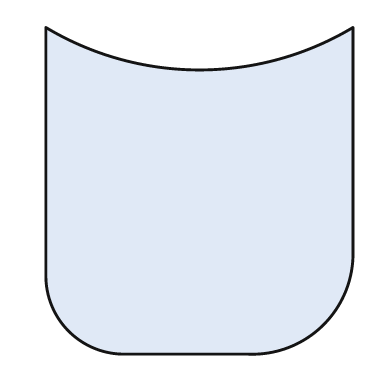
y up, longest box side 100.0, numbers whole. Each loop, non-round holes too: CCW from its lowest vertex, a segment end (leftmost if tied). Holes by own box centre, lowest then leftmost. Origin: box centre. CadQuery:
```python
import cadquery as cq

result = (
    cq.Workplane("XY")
    .moveTo(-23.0, -50.0)
    .lineTo(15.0, -50.0)
    .threePointArc((38.0, -41.0), (47.0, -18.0))
    .lineTo(47.0, 50.0)
    .threePointArc((0.0, 37.0), (-47.0, 50.0))
    .lineTo(-47.0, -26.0)
    .threePointArc((-40.0, -43.0), (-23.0, -50.0))
    .close()
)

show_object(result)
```